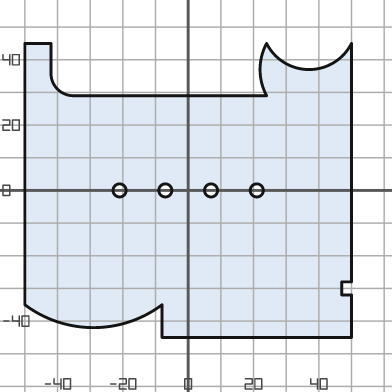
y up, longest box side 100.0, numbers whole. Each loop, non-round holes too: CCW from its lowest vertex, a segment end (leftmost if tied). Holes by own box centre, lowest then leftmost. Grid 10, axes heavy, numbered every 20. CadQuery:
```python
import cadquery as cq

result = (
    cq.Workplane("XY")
    .moveTo(-8.0, -45.0)
    .lineTo(50.0, -45.0)
    .lineTo(50.0, -32.0)
    .lineTo(47.0, -32.0)
    .lineTo(47.0, -28.0)
    .lineTo(50.0, -28.0)
    .lineTo(50.0, 45.0)
    .threePointArc((37.0, 37.0), (24.0, 45.0))
    .threePointArc((22.0, 37.0), (24.0, 29.0))
    .lineTo(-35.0, 29.0)
    .threePointArc((-40.0, 31.0), (-42.0, 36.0))
    .lineTo(-42.0, 45.0)
    .lineTo(-50.0, 45.0)
    .lineTo(-50.0, -35.0)
    .threePointArc((-29.0, -42.0), (-8.0, -35.0))
    .close()
    .moveTo(-21.0, 0.0)
    .circle(2.0)
    .moveTo(-7.0, 0.0)
    .circle(2.0)
    .moveTo(7.0, 0.0)
    .circle(2.0)
    .moveTo(21.0, 0.0)
    .circle(2.0)
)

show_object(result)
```